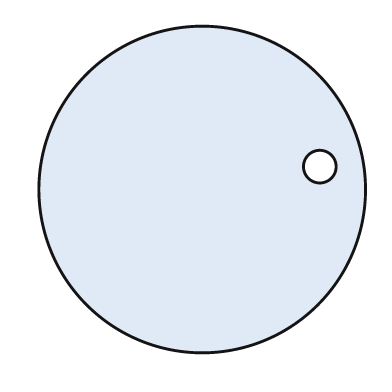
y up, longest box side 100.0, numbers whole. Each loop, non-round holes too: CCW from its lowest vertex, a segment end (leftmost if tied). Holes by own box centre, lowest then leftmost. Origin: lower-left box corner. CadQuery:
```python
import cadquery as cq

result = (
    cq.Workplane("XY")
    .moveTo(50.0, 50.0)
    .circle(50.0)
    .moveTo(86.0, 57.0)
    .circle(5.0)
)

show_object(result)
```